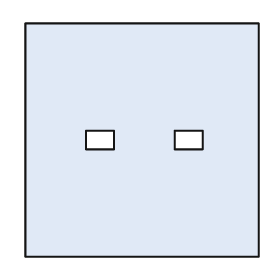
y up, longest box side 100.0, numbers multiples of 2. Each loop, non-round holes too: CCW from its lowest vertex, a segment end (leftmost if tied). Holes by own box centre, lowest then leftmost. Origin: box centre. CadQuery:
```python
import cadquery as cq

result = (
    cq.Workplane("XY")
    .moveTo(-50.0, -50.0)
    .lineTo(50.0, -50.0)
    .lineTo(50.0, 50.0)
    .lineTo(-50.0, 50.0)
    .close()
    .moveTo(-24.0, -4.0)
    .lineTo(-12.0, -4.0)
    .lineTo(-12.0, 4.0)
    .lineTo(-24.0, 4.0)
    .close()
    .moveTo(14.0, -4.0)
    .lineTo(26.0, -4.0)
    .lineTo(26.0, 4.0)
    .lineTo(14.0, 4.0)
    .close()
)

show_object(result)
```